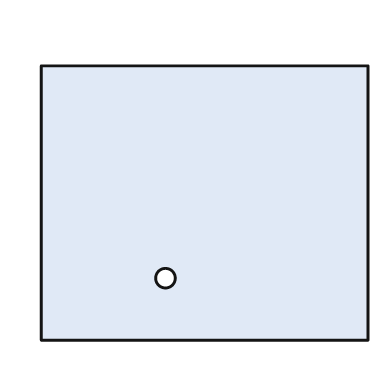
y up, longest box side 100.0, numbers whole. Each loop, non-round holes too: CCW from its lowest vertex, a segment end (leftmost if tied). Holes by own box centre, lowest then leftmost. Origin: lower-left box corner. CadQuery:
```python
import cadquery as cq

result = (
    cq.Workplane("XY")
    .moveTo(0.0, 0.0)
    .lineTo(100.0, 0.0)
    .lineTo(100.0, 84.0)
    .lineTo(0.0, 84.0)
    .close()
    .moveTo(38.0, 19.0)
    .circle(3.0)
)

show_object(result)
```